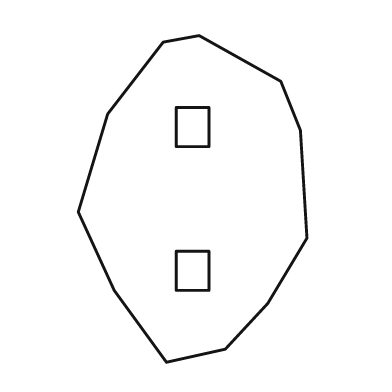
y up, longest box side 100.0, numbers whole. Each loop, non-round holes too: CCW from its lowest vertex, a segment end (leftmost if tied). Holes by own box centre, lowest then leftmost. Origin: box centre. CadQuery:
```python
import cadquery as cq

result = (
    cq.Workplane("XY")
    .moveTo(-8.0, -50.0)
    .lineTo(10.0, -46.0)
    .lineTo(23.0, -32.0)
    .lineTo(35.0, -12.0)
    .lineTo(33.0, 21.0)
    .lineTo(27.0, 36.0)
    .lineTo(2.0, 50.0)
    .lineTo(-9.0, 48.0)
    .lineTo(-26.0, 26.0)
    .lineTo(-35.0, -4.0)
    .lineTo(-24.0, -28.0)
    .close()
    .moveTo(-5.0, -28.0)
    .lineTo(5.0, -28.0)
    .lineTo(5.0, -16.0)
    .lineTo(-5.0, -16.0)
    .close()
    .moveTo(-5.0, 16.0)
    .lineTo(5.0, 16.0)
    .lineTo(5.0, 28.0)
    .lineTo(-5.0, 28.0)
    .close()
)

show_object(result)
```